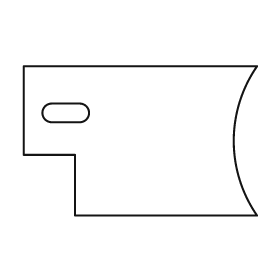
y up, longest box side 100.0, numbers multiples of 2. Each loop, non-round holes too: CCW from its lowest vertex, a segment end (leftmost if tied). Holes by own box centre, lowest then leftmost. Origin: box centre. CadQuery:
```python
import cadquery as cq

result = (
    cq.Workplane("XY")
    .moveTo(-28.0, -32.0)
    .lineTo(50.0, -32.0)
    .threePointArc((40.0, 0.0), (50.0, 32.0))
    .lineTo(-50.0, 32.0)
    .lineTo(-50.0, -6.0)
    .lineTo(-28.0, -6.0)
    .close()
    .moveTo(-38.0, 8.0)
    .lineTo(-26.0, 8.0)
    .threePointArc((-22.0, 12.0), (-26.0, 16.0))
    .lineTo(-38.0, 16.0)
    .threePointArc((-42.0, 12.0), (-38.0, 8.0))
    .close()
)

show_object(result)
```